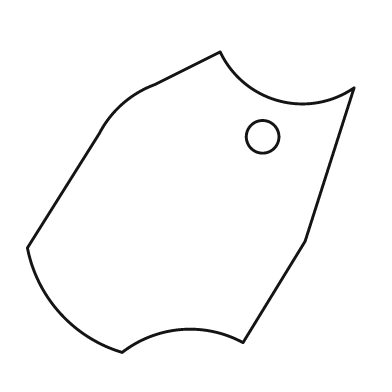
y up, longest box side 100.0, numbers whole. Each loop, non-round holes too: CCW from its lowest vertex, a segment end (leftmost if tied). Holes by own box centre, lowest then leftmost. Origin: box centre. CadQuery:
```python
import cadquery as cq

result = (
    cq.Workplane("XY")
    .moveTo(-21.0, -46.0)
    .threePointArc((-3.0, -39.0), (16.0, -43.0))
    .lineTo(35.0, -12.0)
    .lineTo(50.0, 35.0)
    .threePointArc((27.0, 31.0), (9.0, 46.0))
    .lineTo(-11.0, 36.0)
    .threePointArc((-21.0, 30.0), (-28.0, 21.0))
    .lineTo(-50.0, -14.0)
    .threePointArc((-40.0, -34.0), (-21.0, -46.0))
    .close()
    .moveTo(22.0, 20.0)
    .circle(5.0)
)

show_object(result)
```